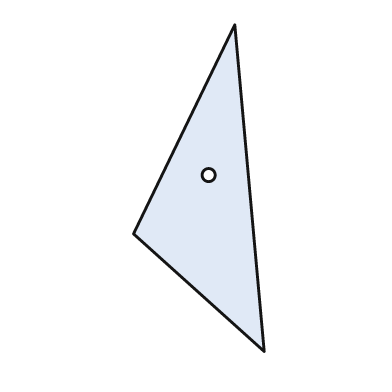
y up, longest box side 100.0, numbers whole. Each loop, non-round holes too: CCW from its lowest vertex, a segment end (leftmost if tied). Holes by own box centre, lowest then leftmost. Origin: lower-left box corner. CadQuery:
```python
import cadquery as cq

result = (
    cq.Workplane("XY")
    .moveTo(40.0, 0.0)
    .lineTo(31.0, 100.0)
    .lineTo(0.0, 36.0)
    .close()
    .moveTo(23.0, 54.0)
    .circle(2.0)
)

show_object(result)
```